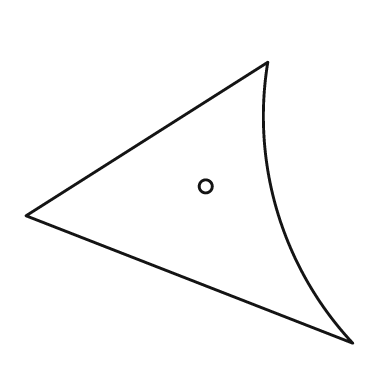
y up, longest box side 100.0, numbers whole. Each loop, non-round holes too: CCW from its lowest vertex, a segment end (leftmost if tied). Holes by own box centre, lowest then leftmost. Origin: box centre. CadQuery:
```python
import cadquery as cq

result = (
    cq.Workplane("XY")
    .moveTo(50.0, -43.0)
    .threePointArc((27.0, -3.0), (24.0, 43.0))
    .lineTo(-50.0, -4.0)
    .close()
    .moveTo(5.0, 5.0)
    .circle(2.0)
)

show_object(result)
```